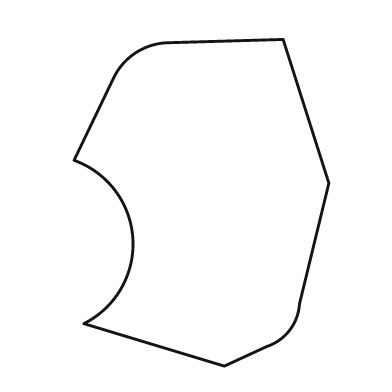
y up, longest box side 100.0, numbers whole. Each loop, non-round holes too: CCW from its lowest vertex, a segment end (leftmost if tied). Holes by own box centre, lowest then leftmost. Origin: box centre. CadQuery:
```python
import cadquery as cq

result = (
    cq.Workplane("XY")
    .moveTo(7.0, -50.0)
    .lineTo(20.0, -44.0)
    .threePointArc((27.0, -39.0), (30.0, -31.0))
    .lineTo(39.0, 6.0)
    .lineTo(25.0, 50.0)
    .lineTo(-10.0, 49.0)
    .threePointArc((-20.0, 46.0), (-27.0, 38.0))
    .lineTo(-39.0, 13.0)
    .threePointArc((-21.0, -11.0), (-36.0, -37.0))
    .close()
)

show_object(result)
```